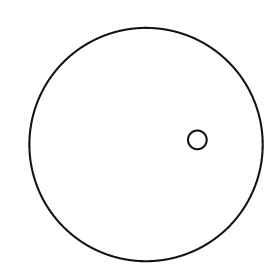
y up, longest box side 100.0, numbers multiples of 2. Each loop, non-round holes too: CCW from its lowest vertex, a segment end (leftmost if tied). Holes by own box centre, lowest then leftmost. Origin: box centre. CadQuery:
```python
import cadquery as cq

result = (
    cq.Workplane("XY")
    .moveTo(0.0, 0.0)
    .circle(50.0)
    .moveTo(22.0, 2.0)
    .circle(4.0)
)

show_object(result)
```